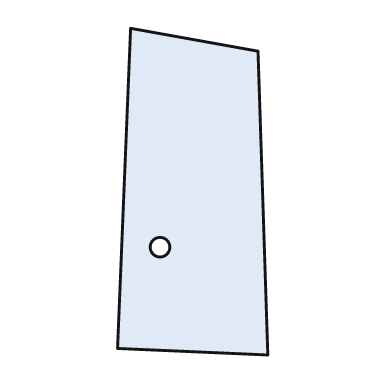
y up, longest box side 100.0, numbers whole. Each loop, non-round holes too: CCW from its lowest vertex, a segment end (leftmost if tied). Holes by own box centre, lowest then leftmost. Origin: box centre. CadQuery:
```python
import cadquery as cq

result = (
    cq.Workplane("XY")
    .moveTo(23.0, -50.0)
    .lineTo(20.0, 43.0)
    .lineTo(-19.0, 50.0)
    .lineTo(-23.0, -48.0)
    .close()
    .moveTo(-10.0, -17.0)
    .circle(3.0)
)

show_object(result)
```